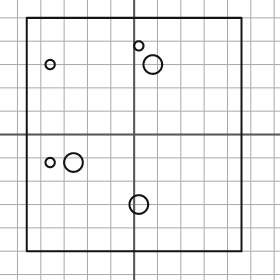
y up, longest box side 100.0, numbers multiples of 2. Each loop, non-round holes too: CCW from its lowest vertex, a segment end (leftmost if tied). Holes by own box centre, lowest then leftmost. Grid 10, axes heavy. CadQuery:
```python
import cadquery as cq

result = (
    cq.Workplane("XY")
    .moveTo(-46.0, -50.0)
    .lineTo(46.0, -50.0)
    .lineTo(46.0, 50.0)
    .lineTo(-46.0, 50.0)
    .close()
    .moveTo(2.0, -30.0)
    .circle(4.0)
    .moveTo(-36.0, -12.0)
    .circle(2.0)
    .moveTo(-26.0, -12.0)
    .circle(4.0)
    .moveTo(-36.0, 30.0)
    .circle(2.0)
    .moveTo(8.0, 30.0)
    .circle(4.0)
    .moveTo(2.0, 38.0)
    .circle(2.0)
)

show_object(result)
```